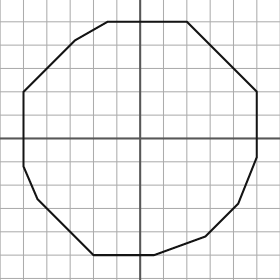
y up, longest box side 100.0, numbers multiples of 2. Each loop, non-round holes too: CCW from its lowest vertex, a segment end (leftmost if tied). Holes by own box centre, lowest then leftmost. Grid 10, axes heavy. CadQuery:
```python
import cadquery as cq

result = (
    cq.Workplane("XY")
    .moveTo(-20.0, -50.0)
    .lineTo(6.0, -50.0)
    .lineTo(28.0, -42.0)
    .lineTo(42.0, -28.0)
    .lineTo(50.0, -8.0)
    .lineTo(50.0, 20.0)
    .lineTo(20.0, 50.0)
    .lineTo(-14.0, 50.0)
    .lineTo(-28.0, 42.0)
    .lineTo(-50.0, 20.0)
    .lineTo(-50.0, -12.0)
    .lineTo(-44.0, -26.0)
    .close()
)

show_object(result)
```